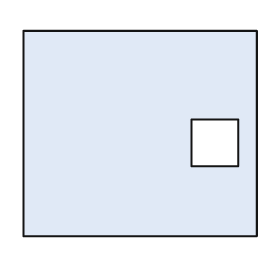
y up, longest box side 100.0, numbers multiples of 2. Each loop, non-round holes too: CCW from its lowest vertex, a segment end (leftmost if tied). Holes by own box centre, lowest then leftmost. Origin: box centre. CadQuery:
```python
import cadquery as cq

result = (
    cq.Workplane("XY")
    .moveTo(-50.0, -44.0)
    .lineTo(50.0, -44.0)
    .lineTo(50.0, 44.0)
    .lineTo(-50.0, 44.0)
    .close()
    .moveTo(22.0, -14.0)
    .lineTo(42.0, -14.0)
    .lineTo(42.0, 6.0)
    .lineTo(22.0, 6.0)
    .close()
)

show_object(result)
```